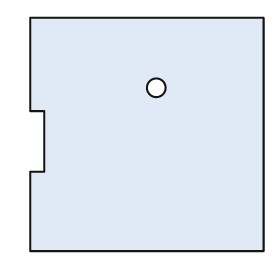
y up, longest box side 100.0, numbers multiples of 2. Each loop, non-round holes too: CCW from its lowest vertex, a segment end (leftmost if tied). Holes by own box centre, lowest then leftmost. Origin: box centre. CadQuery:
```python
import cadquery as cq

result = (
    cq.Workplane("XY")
    .moveTo(-50.0, -50.0)
    .lineTo(50.0, -50.0)
    .lineTo(50.0, 50.0)
    .lineTo(-50.0, 50.0)
    .lineTo(-50.0, 10.0)
    .lineTo(-44.0, 10.0)
    .lineTo(-44.0, -16.0)
    .lineTo(-50.0, -16.0)
    .close()
    .moveTo(4.0, 20.0)
    .circle(4.0)
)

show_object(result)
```